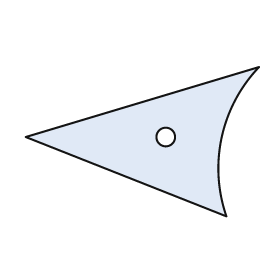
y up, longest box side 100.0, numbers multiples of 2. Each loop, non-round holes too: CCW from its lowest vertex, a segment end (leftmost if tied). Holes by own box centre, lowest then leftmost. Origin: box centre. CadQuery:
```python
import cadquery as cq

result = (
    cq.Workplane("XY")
    .moveTo(36.0, -32.0)
    .threePointArc((34.0, 2.0), (50.0, 32.0))
    .lineTo(-50.0, 2.0)
    .close()
    .moveTo(10.0, 2.0)
    .circle(4.0)
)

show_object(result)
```